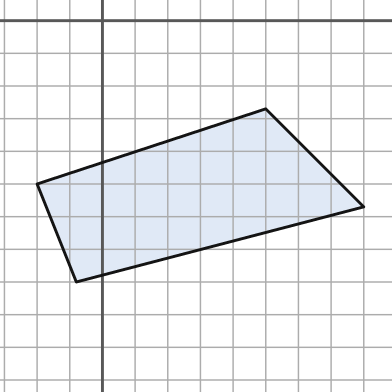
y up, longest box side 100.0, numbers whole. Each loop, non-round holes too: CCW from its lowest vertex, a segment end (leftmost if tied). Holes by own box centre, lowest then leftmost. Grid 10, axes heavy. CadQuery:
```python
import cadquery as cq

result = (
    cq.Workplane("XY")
    .moveTo(-8.0, -80.0)
    .lineTo(80.0, -57.0)
    .lineTo(50.0, -27.0)
    .lineTo(-20.0, -50.0)
    .close()
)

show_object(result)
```